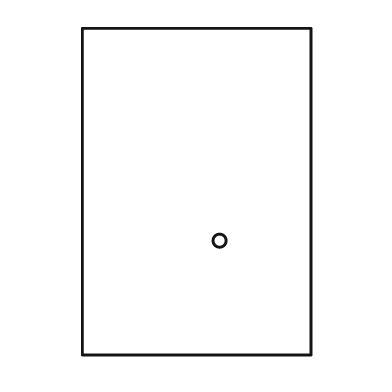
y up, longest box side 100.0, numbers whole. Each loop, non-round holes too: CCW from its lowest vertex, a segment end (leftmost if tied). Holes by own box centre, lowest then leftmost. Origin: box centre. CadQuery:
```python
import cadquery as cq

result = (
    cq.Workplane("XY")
    .moveTo(-35.0, -50.0)
    .lineTo(35.0, -50.0)
    .lineTo(35.0, 50.0)
    .lineTo(-35.0, 50.0)
    .close()
    .moveTo(7.0, -15.0)
    .circle(2.0)
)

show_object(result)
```